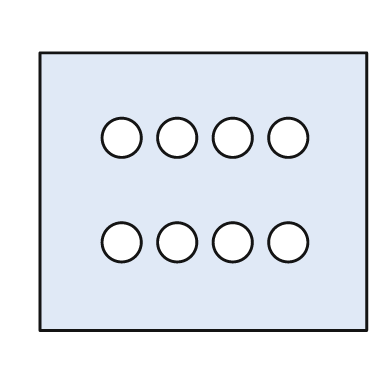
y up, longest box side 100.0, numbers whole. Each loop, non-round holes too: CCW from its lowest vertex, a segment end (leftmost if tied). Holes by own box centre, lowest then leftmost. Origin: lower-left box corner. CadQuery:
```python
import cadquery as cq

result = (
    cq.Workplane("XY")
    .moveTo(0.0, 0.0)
    .lineTo(100.0, 0.0)
    .lineTo(100.0, 85.0)
    .lineTo(0.0, 85.0)
    .close()
    .moveTo(25.0, 27.0)
    .circle(6.0)
    .moveTo(42.0, 27.0)
    .circle(6.0)
    .moveTo(59.0, 27.0)
    .circle(6.0)
    .moveTo(76.0, 27.0)
    .circle(6.0)
    .moveTo(25.0, 59.0)
    .circle(6.0)
    .moveTo(42.0, 59.0)
    .circle(6.0)
    .moveTo(59.0, 59.0)
    .circle(6.0)
    .moveTo(76.0, 59.0)
    .circle(6.0)
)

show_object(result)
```